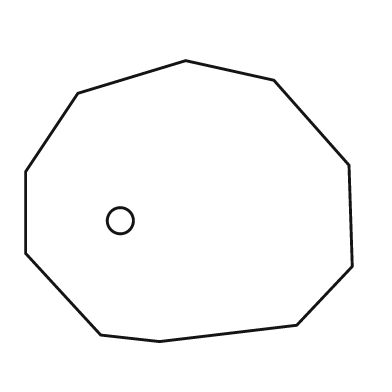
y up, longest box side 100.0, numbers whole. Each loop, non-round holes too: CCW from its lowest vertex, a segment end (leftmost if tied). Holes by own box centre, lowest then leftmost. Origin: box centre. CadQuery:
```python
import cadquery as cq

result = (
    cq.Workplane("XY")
    .moveTo(-9.0, -43.0)
    .lineTo(33.0, -38.0)
    .lineTo(50.0, -20.0)
    .lineTo(49.0, 11.0)
    .lineTo(26.0, 37.0)
    .lineTo(-1.0, 43.0)
    .lineTo(-34.0, 33.0)
    .lineTo(-50.0, 9.0)
    .lineTo(-50.0, -16.0)
    .lineTo(-27.0, -41.0)
    .close()
    .moveTo(-21.0, -6.0)
    .circle(4.0)
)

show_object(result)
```